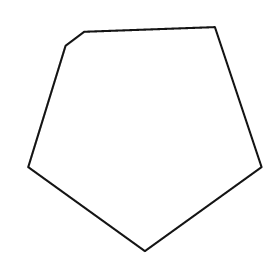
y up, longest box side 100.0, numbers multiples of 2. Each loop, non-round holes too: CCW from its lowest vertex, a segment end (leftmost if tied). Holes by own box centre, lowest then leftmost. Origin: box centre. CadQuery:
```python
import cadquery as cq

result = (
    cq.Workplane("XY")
    .moveTo(0.0, -48.0)
    .lineTo(50.0, -12.0)
    .lineTo(30.0, 48.0)
    .lineTo(-26.0, 46.0)
    .lineTo(-34.0, 40.0)
    .lineTo(-50.0, -12.0)
    .close()
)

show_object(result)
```